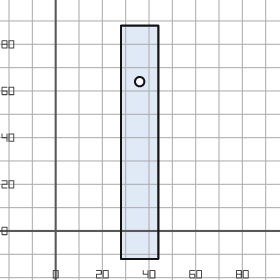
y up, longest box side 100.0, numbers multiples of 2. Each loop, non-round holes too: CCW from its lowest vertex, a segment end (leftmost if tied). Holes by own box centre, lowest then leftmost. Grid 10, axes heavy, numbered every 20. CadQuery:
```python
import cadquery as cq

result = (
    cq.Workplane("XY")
    .moveTo(28.0, -12.0)
    .lineTo(44.0, -12.0)
    .lineTo(44.0, 88.0)
    .lineTo(28.0, 88.0)
    .close()
    .moveTo(36.0, 64.0)
    .circle(2.0)
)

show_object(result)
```